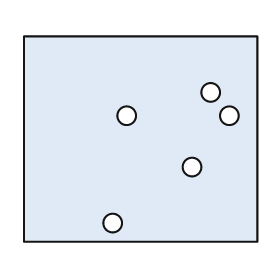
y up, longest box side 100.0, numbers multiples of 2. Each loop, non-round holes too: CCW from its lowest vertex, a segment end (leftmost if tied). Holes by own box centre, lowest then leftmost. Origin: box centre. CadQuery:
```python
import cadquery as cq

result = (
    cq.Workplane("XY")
    .moveTo(-50.0, -44.0)
    .lineTo(50.0, -44.0)
    .lineTo(50.0, 44.0)
    .lineTo(-50.0, 44.0)
    .close()
    .moveTo(-12.0, -36.0)
    .circle(4.0)
    .moveTo(22.0, -12.0)
    .circle(4.0)
    .moveTo(-6.0, 10.0)
    .circle(4.0)
    .moveTo(38.0, 10.0)
    .circle(4.0)
    .moveTo(30.0, 20.0)
    .circle(4.0)
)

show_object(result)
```